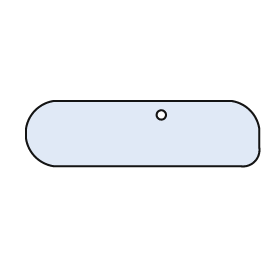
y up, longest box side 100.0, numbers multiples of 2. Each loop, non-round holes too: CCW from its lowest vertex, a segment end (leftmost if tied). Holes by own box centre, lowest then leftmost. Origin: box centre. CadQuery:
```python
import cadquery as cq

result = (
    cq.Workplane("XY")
    .moveTo(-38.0, -14.0)
    .lineTo(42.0, -14.0)
    .threePointArc((48.0, -12.0), (50.0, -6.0))
    .lineTo(50.0, 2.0)
    .threePointArc((46.0, 10.0), (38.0, 14.0))
    .lineTo(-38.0, 14.0)
    .threePointArc((-46.0, 10.0), (-50.0, 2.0))
    .lineTo(-50.0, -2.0)
    .threePointArc((-46.0, -10.0), (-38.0, -14.0))
    .close()
    .moveTo(8.0, 8.0)
    .circle(2.0)
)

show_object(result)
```